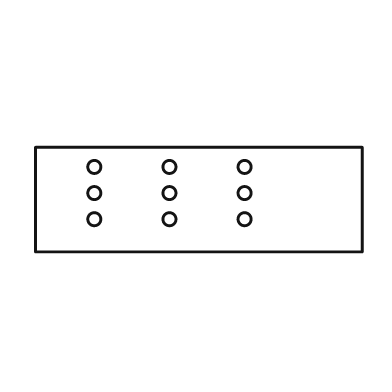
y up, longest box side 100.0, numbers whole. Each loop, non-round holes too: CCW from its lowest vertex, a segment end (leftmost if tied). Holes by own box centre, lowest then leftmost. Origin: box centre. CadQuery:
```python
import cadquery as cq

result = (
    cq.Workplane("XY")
    .moveTo(-50.0, -16.0)
    .lineTo(50.0, -16.0)
    .lineTo(50.0, 16.0)
    .lineTo(-50.0, 16.0)
    .close()
    .moveTo(-32.0, -6.0)
    .circle(2.0)
    .moveTo(-9.0, -6.0)
    .circle(2.0)
    .moveTo(14.0, -6.0)
    .circle(2.0)
    .moveTo(-32.0, 2.0)
    .circle(2.0)
    .moveTo(-9.0, 2.0)
    .circle(2.0)
    .moveTo(14.0, 2.0)
    .circle(2.0)
    .moveTo(-32.0, 10.0)
    .circle(2.0)
    .moveTo(-9.0, 10.0)
    .circle(2.0)
    .moveTo(14.0, 10.0)
    .circle(2.0)
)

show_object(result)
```